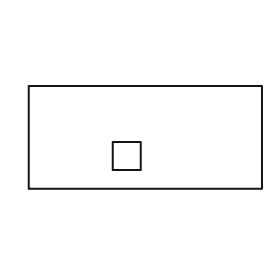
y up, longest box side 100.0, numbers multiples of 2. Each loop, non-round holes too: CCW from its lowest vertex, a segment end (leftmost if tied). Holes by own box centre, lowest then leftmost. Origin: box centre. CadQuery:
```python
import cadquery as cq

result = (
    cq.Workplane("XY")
    .moveTo(-50.0, -22.0)
    .lineTo(50.0, -22.0)
    .lineTo(50.0, 22.0)
    .lineTo(-50.0, 22.0)
    .close()
    .moveTo(-14.0, -14.0)
    .lineTo(-2.0, -14.0)
    .lineTo(-2.0, -2.0)
    .lineTo(-14.0, -2.0)
    .close()
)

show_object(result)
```